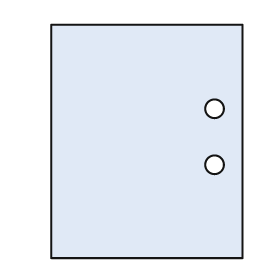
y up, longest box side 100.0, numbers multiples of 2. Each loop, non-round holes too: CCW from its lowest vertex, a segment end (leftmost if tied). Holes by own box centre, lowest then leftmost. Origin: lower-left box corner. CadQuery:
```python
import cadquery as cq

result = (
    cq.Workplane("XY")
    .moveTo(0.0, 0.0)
    .lineTo(82.0, 0.0)
    .lineTo(82.0, 100.0)
    .lineTo(0.0, 100.0)
    .close()
    .moveTo(70.0, 40.0)
    .circle(4.0)
    .moveTo(70.0, 64.0)
    .circle(4.0)
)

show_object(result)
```